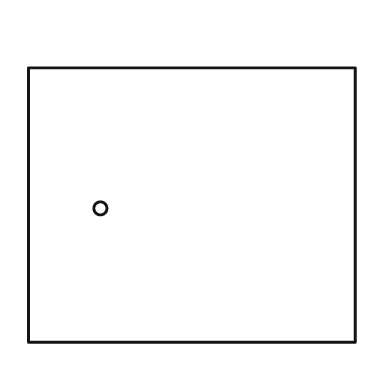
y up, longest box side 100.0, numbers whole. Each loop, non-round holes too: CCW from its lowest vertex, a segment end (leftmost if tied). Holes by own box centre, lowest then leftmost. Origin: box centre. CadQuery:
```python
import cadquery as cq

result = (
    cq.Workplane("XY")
    .moveTo(-50.0, -42.0)
    .lineTo(50.0, -42.0)
    .lineTo(50.0, 42.0)
    .lineTo(-50.0, 42.0)
    .close()
    .moveTo(-28.0, -1.0)
    .circle(2.0)
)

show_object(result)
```